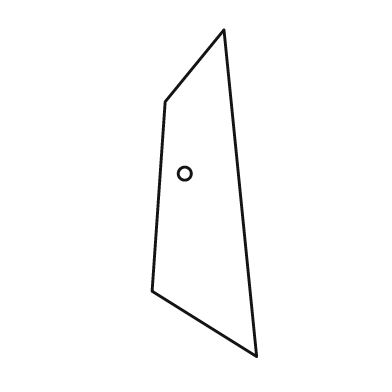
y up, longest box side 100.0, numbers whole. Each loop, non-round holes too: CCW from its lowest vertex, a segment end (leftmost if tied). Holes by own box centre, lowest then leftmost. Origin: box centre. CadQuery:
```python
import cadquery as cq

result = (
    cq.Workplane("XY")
    .moveTo(16.0, -50.0)
    .lineTo(6.0, 50.0)
    .lineTo(-12.0, 28.0)
    .lineTo(-16.0, -30.0)
    .close()
    .moveTo(-6.0, 6.0)
    .circle(2.0)
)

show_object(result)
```